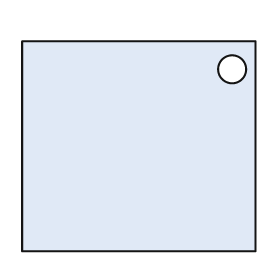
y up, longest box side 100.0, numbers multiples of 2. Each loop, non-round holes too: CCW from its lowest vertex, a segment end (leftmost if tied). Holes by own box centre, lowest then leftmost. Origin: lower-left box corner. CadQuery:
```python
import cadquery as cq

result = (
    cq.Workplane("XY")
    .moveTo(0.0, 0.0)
    .lineTo(100.0, 0.0)
    .lineTo(100.0, 90.0)
    .lineTo(0.0, 90.0)
    .close()
    .moveTo(90.0, 78.0)
    .circle(6.0)
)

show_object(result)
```